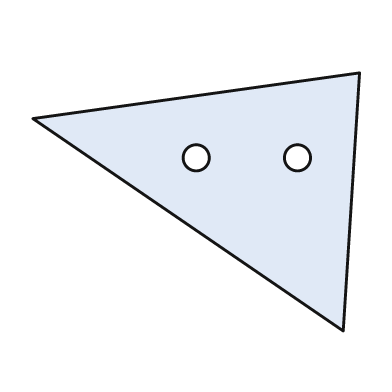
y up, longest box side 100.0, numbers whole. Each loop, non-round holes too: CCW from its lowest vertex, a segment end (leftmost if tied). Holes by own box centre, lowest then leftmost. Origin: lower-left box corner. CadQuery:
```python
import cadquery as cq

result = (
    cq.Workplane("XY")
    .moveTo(95.0, 0.0)
    .lineTo(100.0, 79.0)
    .lineTo(0.0, 65.0)
    .close()
    .moveTo(50.0, 53.0)
    .circle(4.0)
    .moveTo(81.0, 53.0)
    .circle(4.0)
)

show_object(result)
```